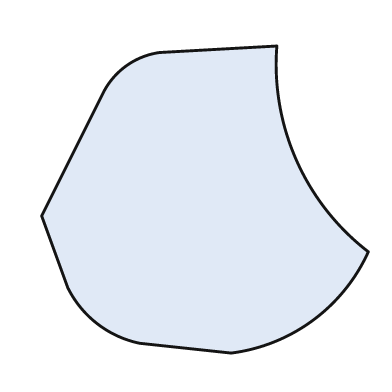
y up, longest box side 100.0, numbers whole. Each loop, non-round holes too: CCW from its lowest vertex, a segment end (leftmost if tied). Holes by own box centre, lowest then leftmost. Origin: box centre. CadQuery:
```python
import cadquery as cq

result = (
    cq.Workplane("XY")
    .moveTo(8.0, -47.0)
    .threePointArc((33.0, -37.0), (50.0, -16.0))
    .threePointArc((28.0, 12.0), (22.0, 47.0))
    .lineTo(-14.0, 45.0)
    .threePointArc((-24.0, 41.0), (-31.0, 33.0))
    .lineTo(-50.0, -5.0)
    .lineTo(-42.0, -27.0)
    .threePointArc((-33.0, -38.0), (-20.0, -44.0))
    .close()
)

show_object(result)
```